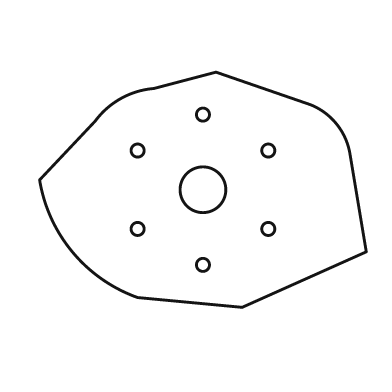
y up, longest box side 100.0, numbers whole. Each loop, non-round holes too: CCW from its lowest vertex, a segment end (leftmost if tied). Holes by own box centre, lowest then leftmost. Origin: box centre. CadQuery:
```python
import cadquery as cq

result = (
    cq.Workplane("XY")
    .moveTo(12.0, -36.0)
    .lineTo(50.0, -19.0)
    .lineTo(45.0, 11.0)
    .threePointArc((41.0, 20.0), (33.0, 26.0))
    .lineTo(4.0, 36.0)
    .lineTo(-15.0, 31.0)
    .threePointArc((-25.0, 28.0), (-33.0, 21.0))
    .lineTo(-50.0, 3.0)
    .threePointArc((-40.0, -19.0), (-20.0, -33.0))
    .close()
    .moveTo(0.0, -23.0)
    .circle(2.0)
    .moveTo(-20.0, -12.0)
    .circle(2.0)
    .moveTo(20.0, -12.0)
    .circle(2.0)
    .moveTo(0.0, 0.0)
    .circle(7.0)
    .moveTo(-20.0, 12.0)
    .circle(2.0)
    .moveTo(20.0, 12.0)
    .circle(2.0)
    .moveTo(0.0, 23.0)
    .circle(2.0)
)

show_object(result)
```